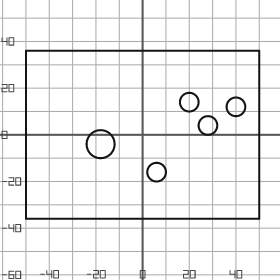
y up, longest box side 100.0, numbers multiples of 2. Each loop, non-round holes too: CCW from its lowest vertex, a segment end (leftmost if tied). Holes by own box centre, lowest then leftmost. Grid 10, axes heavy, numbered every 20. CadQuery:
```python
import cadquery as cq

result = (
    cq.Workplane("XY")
    .moveTo(-50.0, -36.0)
    .lineTo(50.0, -36.0)
    .lineTo(50.0, 36.0)
    .lineTo(-50.0, 36.0)
    .close()
    .moveTo(6.0, -16.0)
    .circle(4.0)
    .moveTo(-18.0, -4.0)
    .circle(6.0)
    .moveTo(28.0, 4.0)
    .circle(4.0)
    .moveTo(40.0, 12.0)
    .circle(4.0)
    .moveTo(20.0, 14.0)
    .circle(4.0)
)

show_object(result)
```